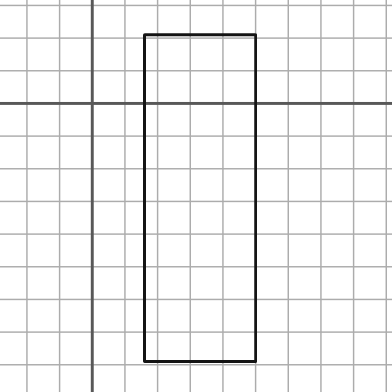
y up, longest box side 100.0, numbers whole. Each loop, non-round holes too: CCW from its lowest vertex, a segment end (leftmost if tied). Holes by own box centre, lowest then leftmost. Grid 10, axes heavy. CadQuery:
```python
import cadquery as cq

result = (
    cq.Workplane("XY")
    .moveTo(16.0, -79.0)
    .lineTo(50.0, -79.0)
    .lineTo(50.0, 21.0)
    .lineTo(16.0, 21.0)
    .close()
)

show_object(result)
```